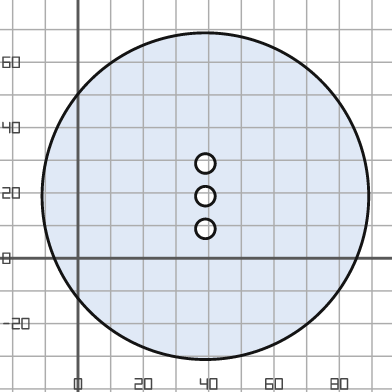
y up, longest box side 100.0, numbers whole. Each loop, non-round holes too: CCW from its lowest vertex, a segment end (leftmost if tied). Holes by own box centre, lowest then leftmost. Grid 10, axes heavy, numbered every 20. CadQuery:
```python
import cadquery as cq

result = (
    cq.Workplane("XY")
    .moveTo(39.0, 19.0)
    .circle(50.0)
    .moveTo(39.0, 9.0)
    .circle(3.0)
    .moveTo(39.0, 19.0)
    .circle(3.0)
    .moveTo(39.0, 29.0)
    .circle(3.0)
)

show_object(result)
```